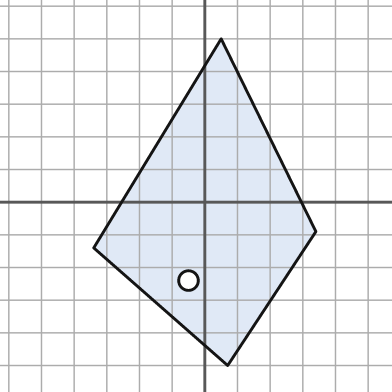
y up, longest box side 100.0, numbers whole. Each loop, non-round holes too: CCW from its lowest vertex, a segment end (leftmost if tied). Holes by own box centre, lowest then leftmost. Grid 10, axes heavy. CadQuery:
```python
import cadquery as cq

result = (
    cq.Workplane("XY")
    .moveTo(7.0, -50.0)
    .lineTo(34.0, -9.0)
    .lineTo(5.0, 50.0)
    .lineTo(-34.0, -14.0)
    .close()
    .moveTo(-5.0, -24.0)
    .circle(3.0)
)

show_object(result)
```